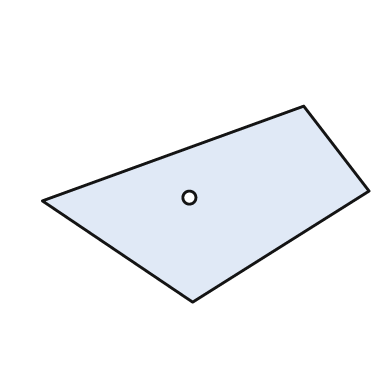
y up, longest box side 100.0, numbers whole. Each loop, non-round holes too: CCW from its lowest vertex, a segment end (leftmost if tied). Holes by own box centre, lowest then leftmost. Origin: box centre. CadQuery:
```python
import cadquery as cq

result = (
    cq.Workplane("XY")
    .moveTo(-4.0, -30.0)
    .lineTo(50.0, 4.0)
    .lineTo(30.0, 30.0)
    .lineTo(-50.0, 1.0)
    .close()
    .moveTo(-5.0, 2.0)
    .circle(2.0)
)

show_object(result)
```